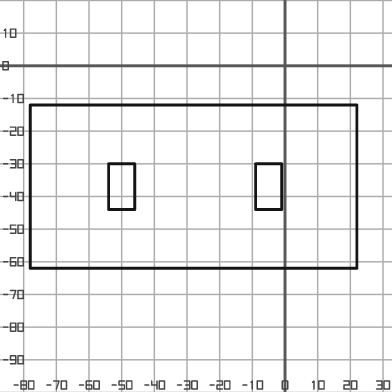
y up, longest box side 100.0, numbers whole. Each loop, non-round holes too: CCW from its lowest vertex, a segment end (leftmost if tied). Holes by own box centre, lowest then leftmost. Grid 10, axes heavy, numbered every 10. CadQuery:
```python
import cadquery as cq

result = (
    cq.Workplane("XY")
    .moveTo(-78.0, -62.0)
    .lineTo(22.0, -62.0)
    .lineTo(22.0, -12.0)
    .lineTo(-78.0, -12.0)
    .close()
    .moveTo(-54.0, -44.0)
    .lineTo(-46.0, -44.0)
    .lineTo(-46.0, -30.0)
    .lineTo(-54.0, -30.0)
    .close()
    .moveTo(-9.0, -44.0)
    .lineTo(-1.0, -44.0)
    .lineTo(-1.0, -30.0)
    .lineTo(-9.0, -30.0)
    .close()
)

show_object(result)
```